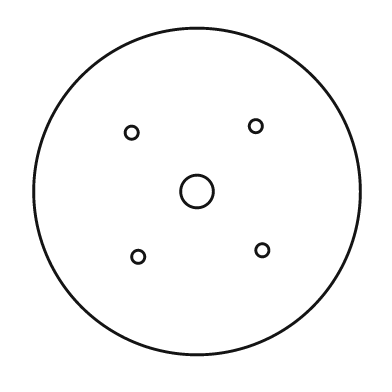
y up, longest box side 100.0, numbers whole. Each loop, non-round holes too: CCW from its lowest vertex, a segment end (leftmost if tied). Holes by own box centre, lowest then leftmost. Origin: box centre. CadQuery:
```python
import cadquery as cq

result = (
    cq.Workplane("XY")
    .moveTo(0.0, 0.0)
    .circle(50.0)
    .moveTo(-18.0, -20.0)
    .circle(2.0)
    .moveTo(20.0, -18.0)
    .circle(2.0)
    .moveTo(0.0, 0.0)
    .circle(5.0)
    .moveTo(-20.0, 18.0)
    .circle(2.0)
    .moveTo(18.0, 20.0)
    .circle(2.0)
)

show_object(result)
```